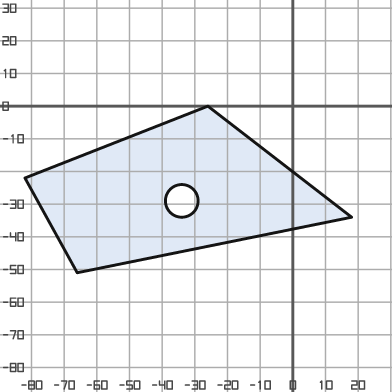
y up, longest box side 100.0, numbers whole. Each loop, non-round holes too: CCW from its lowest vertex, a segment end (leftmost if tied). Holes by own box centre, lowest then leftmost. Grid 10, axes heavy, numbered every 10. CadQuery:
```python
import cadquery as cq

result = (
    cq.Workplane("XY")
    .moveTo(-66.0, -51.0)
    .lineTo(18.0, -34.0)
    .lineTo(-26.0, 0.0)
    .lineTo(-82.0, -22.0)
    .close()
    .moveTo(-34.0, -29.0)
    .circle(5.0)
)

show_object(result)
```